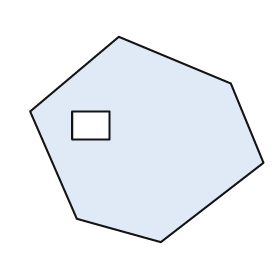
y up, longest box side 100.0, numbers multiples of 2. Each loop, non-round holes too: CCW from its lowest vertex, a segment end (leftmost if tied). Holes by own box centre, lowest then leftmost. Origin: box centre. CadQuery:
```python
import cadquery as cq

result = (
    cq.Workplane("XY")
    .moveTo(6.0, -44.0)
    .lineTo(50.0, -10.0)
    .lineTo(36.0, 24.0)
    .lineTo(-12.0, 44.0)
    .lineTo(-50.0, 12.0)
    .lineTo(-30.0, -34.0)
    .close()
    .moveTo(-32.0, 0.0)
    .lineTo(-16.0, 0.0)
    .lineTo(-16.0, 12.0)
    .lineTo(-32.0, 12.0)
    .close()
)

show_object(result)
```